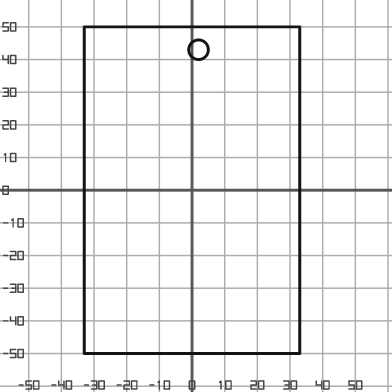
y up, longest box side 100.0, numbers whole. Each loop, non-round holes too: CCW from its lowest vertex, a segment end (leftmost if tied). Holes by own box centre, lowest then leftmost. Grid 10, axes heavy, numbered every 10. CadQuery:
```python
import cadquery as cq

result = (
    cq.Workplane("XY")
    .moveTo(-33.0, -50.0)
    .lineTo(33.0, -50.0)
    .lineTo(33.0, 50.0)
    .lineTo(-33.0, 50.0)
    .close()
    .moveTo(2.0, 43.0)
    .circle(3.0)
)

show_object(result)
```